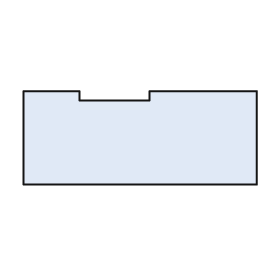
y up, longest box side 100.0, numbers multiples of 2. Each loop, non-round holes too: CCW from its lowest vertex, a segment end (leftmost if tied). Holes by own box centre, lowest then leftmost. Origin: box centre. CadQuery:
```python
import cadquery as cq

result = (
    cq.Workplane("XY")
    .moveTo(-50.0, -20.0)
    .lineTo(50.0, -20.0)
    .lineTo(50.0, 20.0)
    .lineTo(4.0, 20.0)
    .lineTo(4.0, 16.0)
    .lineTo(-26.0, 16.0)
    .lineTo(-26.0, 20.0)
    .lineTo(-50.0, 20.0)
    .close()
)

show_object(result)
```